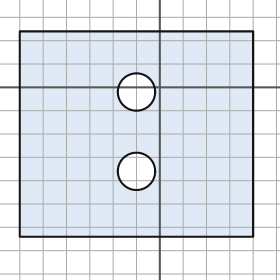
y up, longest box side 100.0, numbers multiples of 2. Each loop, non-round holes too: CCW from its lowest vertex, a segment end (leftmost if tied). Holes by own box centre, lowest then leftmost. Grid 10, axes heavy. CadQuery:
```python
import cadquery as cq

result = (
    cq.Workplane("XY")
    .moveTo(-60.0, -64.0)
    .lineTo(40.0, -64.0)
    .lineTo(40.0, 24.0)
    .lineTo(-60.0, 24.0)
    .close()
    .moveTo(-10.0, -36.0)
    .circle(8.0)
    .moveTo(-10.0, -2.0)
    .circle(8.0)
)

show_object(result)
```